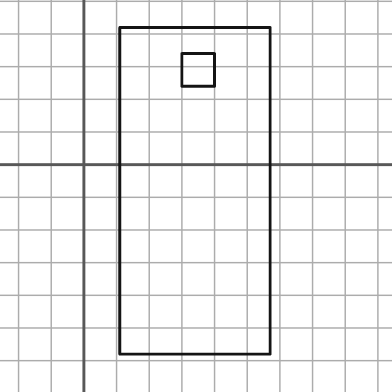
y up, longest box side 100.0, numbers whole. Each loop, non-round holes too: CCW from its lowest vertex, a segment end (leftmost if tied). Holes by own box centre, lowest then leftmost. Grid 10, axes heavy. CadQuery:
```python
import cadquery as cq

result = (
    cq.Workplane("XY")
    .moveTo(11.0, -58.0)
    .lineTo(57.0, -58.0)
    .lineTo(57.0, 42.0)
    .lineTo(11.0, 42.0)
    .close()
    .moveTo(30.0, 24.0)
    .lineTo(40.0, 24.0)
    .lineTo(40.0, 34.0)
    .lineTo(30.0, 34.0)
    .close()
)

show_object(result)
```